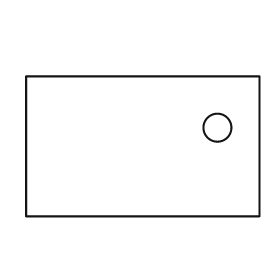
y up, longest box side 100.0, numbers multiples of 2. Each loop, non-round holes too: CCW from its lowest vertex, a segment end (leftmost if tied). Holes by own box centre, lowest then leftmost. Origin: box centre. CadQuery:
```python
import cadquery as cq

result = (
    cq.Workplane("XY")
    .moveTo(-50.0, -30.0)
    .lineTo(50.0, -30.0)
    .lineTo(50.0, 30.0)
    .lineTo(-50.0, 30.0)
    .close()
    .moveTo(32.0, 8.0)
    .circle(6.0)
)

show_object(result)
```